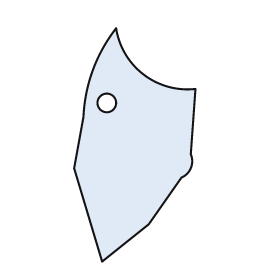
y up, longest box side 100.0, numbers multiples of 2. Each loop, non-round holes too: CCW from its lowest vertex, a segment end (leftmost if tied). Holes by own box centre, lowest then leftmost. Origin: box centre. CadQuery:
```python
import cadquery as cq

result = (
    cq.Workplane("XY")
    .moveTo(-14.0, -50.0)
    .lineTo(6.0, -34.0)
    .lineTo(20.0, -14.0)
    .threePointArc((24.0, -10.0), (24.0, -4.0))
    .lineTo(26.0, 24.0)
    .threePointArc((4.0, 30.0), (-8.0, 50.0))
    .threePointArc((-18.0, 32.0), (-22.0, 12.0))
    .lineTo(-26.0, -10.0)
    .close()
    .moveTo(-12.0, 18.0)
    .circle(4.0)
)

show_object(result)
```